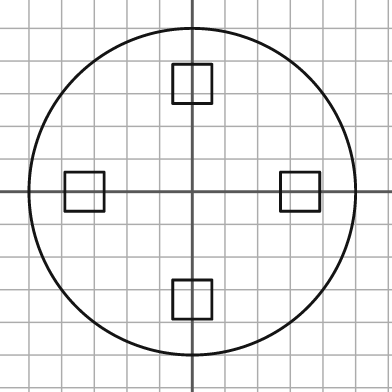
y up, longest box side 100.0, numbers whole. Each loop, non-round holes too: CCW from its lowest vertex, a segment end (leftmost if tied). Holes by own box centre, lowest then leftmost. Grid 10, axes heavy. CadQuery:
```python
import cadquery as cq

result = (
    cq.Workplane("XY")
    .moveTo(0.0, 0.0)
    .circle(50.0)
    .moveTo(-6.0, -39.0)
    .lineTo(6.0, -39.0)
    .lineTo(6.0, -27.0)
    .lineTo(-6.0, -27.0)
    .close()
    .moveTo(-39.0, -6.0)
    .lineTo(-27.0, -6.0)
    .lineTo(-27.0, 6.0)
    .lineTo(-39.0, 6.0)
    .close()
    .moveTo(27.0, -6.0)
    .lineTo(39.0, -6.0)
    .lineTo(39.0, 6.0)
    .lineTo(27.0, 6.0)
    .close()
    .moveTo(-6.0, 27.0)
    .lineTo(6.0, 27.0)
    .lineTo(6.0, 39.0)
    .lineTo(-6.0, 39.0)
    .close()
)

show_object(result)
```